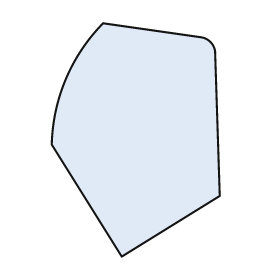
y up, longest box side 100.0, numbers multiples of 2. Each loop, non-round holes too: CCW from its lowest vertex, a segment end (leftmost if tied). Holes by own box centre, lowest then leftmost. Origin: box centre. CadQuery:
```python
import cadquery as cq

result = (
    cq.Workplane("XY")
    .moveTo(-6.0, -50.0)
    .lineTo(36.0, -24.0)
    .lineTo(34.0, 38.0)
    .threePointArc((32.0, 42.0), (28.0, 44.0))
    .lineTo(-14.0, 50.0)
    .threePointArc((-30.0, 26.0), (-36.0, -2.0))
    .close()
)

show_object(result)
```